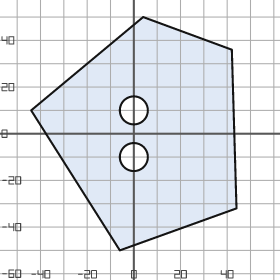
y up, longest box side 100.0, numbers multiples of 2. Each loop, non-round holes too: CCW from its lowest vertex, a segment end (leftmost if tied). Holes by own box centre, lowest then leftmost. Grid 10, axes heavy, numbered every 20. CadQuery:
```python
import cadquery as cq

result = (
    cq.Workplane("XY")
    .moveTo(-6.0, -50.0)
    .lineTo(44.0, -32.0)
    .lineTo(42.0, 36.0)
    .lineTo(4.0, 50.0)
    .lineTo(-44.0, 10.0)
    .close()
    .moveTo(0.0, -10.0)
    .circle(6.0)
    .moveTo(0.0, 10.0)
    .circle(6.0)
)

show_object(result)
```